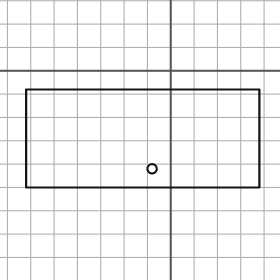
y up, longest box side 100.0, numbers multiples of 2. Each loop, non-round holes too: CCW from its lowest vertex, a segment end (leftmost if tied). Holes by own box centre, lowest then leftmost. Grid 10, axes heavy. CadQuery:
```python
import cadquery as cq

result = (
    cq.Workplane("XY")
    .moveTo(-62.0, -50.0)
    .lineTo(38.0, -50.0)
    .lineTo(38.0, -8.0)
    .lineTo(-62.0, -8.0)
    .close()
    .moveTo(-8.0, -42.0)
    .circle(2.0)
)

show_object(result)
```